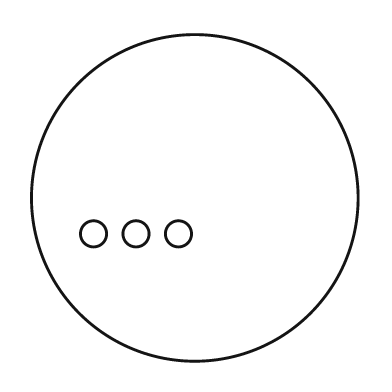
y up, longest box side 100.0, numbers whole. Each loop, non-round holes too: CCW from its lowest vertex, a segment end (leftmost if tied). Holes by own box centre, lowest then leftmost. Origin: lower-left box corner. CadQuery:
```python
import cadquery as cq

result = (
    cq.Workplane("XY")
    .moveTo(50.0, 50.0)
    .circle(50.0)
    .moveTo(19.0, 39.0)
    .circle(4.0)
    .moveTo(32.0, 39.0)
    .circle(4.0)
    .moveTo(45.0, 39.0)
    .circle(4.0)
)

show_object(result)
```